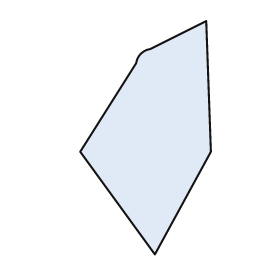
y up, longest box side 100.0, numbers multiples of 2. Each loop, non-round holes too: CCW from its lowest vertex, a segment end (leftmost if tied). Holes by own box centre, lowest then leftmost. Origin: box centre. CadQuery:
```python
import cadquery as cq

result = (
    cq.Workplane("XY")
    .moveTo(4.0, -50.0)
    .lineTo(28.0, -6.0)
    .lineTo(26.0, 50.0)
    .lineTo(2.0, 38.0)
    .threePointArc((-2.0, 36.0), (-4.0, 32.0))
    .lineTo(-28.0, -6.0)
    .close()
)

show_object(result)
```